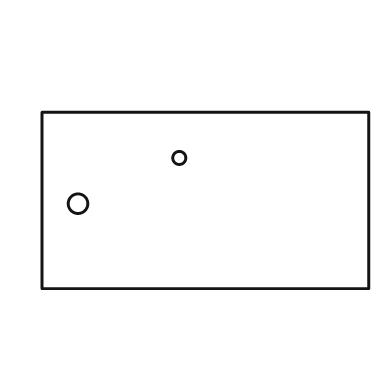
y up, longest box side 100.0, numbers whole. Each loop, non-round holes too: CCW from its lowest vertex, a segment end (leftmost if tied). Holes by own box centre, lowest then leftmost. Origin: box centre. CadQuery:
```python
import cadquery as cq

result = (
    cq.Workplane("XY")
    .moveTo(-50.0, -27.0)
    .lineTo(50.0, -27.0)
    .lineTo(50.0, 27.0)
    .lineTo(-50.0, 27.0)
    .close()
    .moveTo(-39.0, -1.0)
    .circle(3.0)
    .moveTo(-8.0, 13.0)
    .circle(2.0)
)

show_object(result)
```